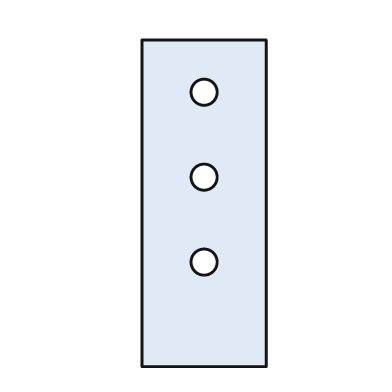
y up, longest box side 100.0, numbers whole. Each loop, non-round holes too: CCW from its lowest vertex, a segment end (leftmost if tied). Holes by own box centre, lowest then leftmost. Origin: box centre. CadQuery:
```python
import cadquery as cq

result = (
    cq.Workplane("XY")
    .moveTo(-19.0, -50.0)
    .lineTo(19.0, -50.0)
    .lineTo(19.0, 50.0)
    .lineTo(-19.0, 50.0)
    .close()
    .moveTo(0.0, -18.0)
    .circle(4.0)
    .moveTo(0.0, 8.0)
    .circle(4.0)
    .moveTo(0.0, 34.0)
    .circle(4.0)
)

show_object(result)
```